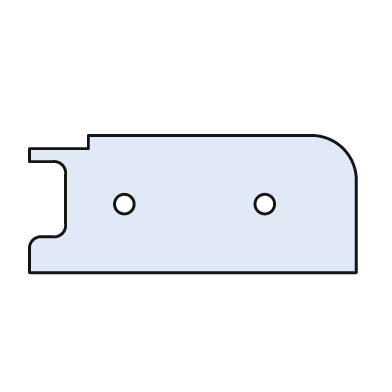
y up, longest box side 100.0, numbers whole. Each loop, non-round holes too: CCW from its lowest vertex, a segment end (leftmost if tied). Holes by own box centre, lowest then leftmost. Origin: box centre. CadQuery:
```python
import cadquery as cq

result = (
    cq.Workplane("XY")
    .moveTo(-50.0, -21.0)
    .lineTo(50.0, -21.0)
    .lineTo(50.0, 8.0)
    .threePointArc((46.0, 17.0), (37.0, 21.0))
    .lineTo(-32.0, 21.0)
    .lineTo(-32.0, 17.0)
    .lineTo(-50.0, 17.0)
    .lineTo(-50.0, 13.0)
    .lineTo(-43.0, 13.0)
    .threePointArc((-40.0, 12.0), (-39.0, 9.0))
    .lineTo(-39.0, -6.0)
    .threePointArc((-40.0, -9.0), (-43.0, -10.0))
    .lineTo(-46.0, -10.0)
    .threePointArc((-49.0, -11.0), (-50.0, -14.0))
    .close()
    .moveTo(-21.0, 0.0)
    .circle(3.0)
    .moveTo(22.0, 0.0)
    .circle(3.0)
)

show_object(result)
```